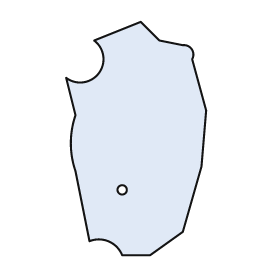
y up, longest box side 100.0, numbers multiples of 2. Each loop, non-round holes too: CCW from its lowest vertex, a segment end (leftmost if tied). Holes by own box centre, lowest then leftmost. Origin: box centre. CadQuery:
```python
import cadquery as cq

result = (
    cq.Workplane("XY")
    .moveTo(-6.0, -50.0)
    .lineTo(6.0, -50.0)
    .lineTo(20.0, -40.0)
    .lineTo(28.0, -12.0)
    .lineTo(30.0, 12.0)
    .lineTo(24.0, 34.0)
    .threePointArc((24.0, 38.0), (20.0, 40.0))
    .lineTo(10.0, 42.0)
    .lineTo(2.0, 50.0)
    .lineTo(-18.0, 42.0)
    .threePointArc((-16.0, 28.0), (-30.0, 26.0))
    .lineTo(-26.0, 10.0)
    .threePointArc((-28.0, -2.0), (-26.0, -14.0))
    .lineTo(-20.0, -44.0)
    .threePointArc((-12.0, -44.0), (-6.0, -50.0))
    .close()
    .moveTo(-6.0, -22.0)
    .circle(2.0)
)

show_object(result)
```